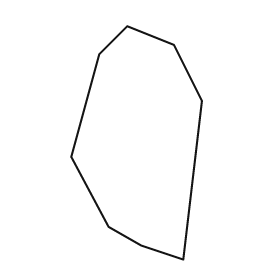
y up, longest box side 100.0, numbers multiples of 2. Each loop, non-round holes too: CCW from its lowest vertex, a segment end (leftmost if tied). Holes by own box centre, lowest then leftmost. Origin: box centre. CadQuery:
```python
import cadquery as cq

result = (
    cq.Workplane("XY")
    .moveTo(20.0, -50.0)
    .lineTo(28.0, 18.0)
    .lineTo(16.0, 42.0)
    .lineTo(-4.0, 50.0)
    .lineTo(-16.0, 38.0)
    .lineTo(-28.0, -6.0)
    .lineTo(-12.0, -36.0)
    .lineTo(2.0, -44.0)
    .close()
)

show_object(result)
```